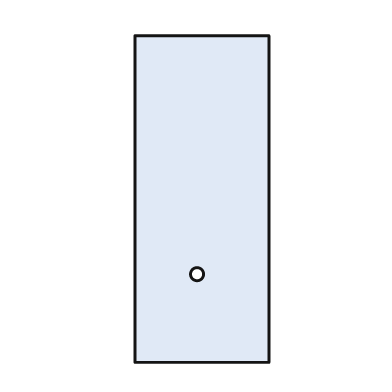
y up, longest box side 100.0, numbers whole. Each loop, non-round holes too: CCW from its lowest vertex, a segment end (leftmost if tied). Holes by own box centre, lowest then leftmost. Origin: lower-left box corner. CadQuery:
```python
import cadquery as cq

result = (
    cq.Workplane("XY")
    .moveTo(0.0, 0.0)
    .lineTo(41.0, 0.0)
    .lineTo(41.0, 100.0)
    .lineTo(0.0, 100.0)
    .close()
    .moveTo(19.0, 27.0)
    .circle(2.0)
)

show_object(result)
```